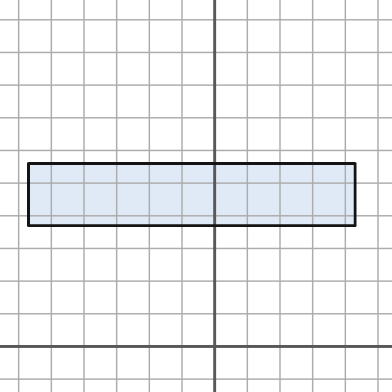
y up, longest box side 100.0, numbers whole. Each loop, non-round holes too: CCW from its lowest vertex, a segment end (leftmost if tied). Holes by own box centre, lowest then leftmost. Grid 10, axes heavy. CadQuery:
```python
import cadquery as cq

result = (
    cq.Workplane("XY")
    .moveTo(-57.0, 37.0)
    .lineTo(43.0, 37.0)
    .lineTo(43.0, 56.0)
    .lineTo(-57.0, 56.0)
    .close()
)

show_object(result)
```